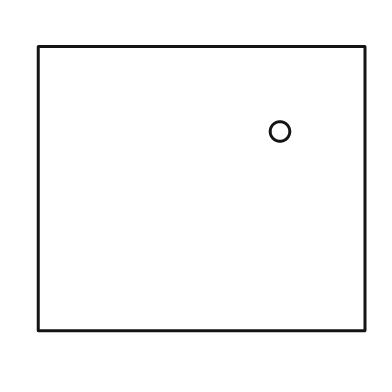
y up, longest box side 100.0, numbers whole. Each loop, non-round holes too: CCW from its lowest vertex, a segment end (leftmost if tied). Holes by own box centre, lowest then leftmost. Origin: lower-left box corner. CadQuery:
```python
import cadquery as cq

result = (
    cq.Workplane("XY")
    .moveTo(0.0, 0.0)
    .lineTo(100.0, 0.0)
    .lineTo(100.0, 87.0)
    .lineTo(0.0, 87.0)
    .close()
    .moveTo(74.0, 61.0)
    .circle(3.0)
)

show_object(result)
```